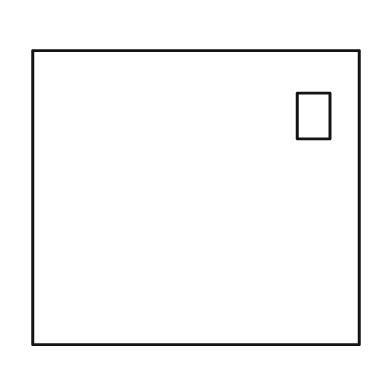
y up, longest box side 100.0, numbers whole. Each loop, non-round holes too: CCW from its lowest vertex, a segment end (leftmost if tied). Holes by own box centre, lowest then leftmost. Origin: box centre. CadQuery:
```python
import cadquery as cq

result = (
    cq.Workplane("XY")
    .moveTo(-50.0, -45.0)
    .lineTo(50.0, -45.0)
    .lineTo(50.0, 45.0)
    .lineTo(-50.0, 45.0)
    .close()
    .moveTo(31.0, 18.0)
    .lineTo(41.0, 18.0)
    .lineTo(41.0, 32.0)
    .lineTo(31.0, 32.0)
    .close()
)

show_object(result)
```